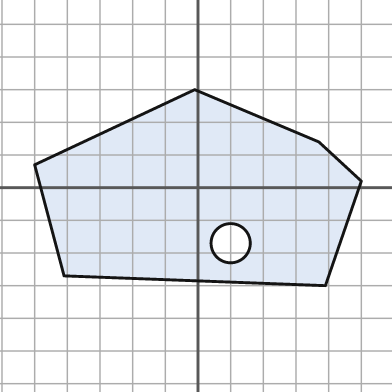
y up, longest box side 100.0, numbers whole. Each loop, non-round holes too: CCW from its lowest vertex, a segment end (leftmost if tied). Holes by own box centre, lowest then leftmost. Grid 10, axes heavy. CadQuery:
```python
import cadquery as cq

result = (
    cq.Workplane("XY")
    .moveTo(39.0, -30.0)
    .lineTo(50.0, 2.0)
    .lineTo(37.0, 14.0)
    .lineTo(-1.0, 30.0)
    .lineTo(-50.0, 7.0)
    .lineTo(-41.0, -27.0)
    .close()
    .moveTo(10.0, -17.0)
    .circle(6.0)
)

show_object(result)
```